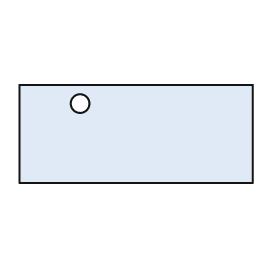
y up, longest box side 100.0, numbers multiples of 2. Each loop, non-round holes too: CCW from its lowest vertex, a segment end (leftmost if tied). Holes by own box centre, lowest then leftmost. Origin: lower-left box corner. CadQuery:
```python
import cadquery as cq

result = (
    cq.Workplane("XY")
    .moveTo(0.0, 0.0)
    .lineTo(100.0, 0.0)
    .lineTo(100.0, 42.0)
    .lineTo(0.0, 42.0)
    .close()
    .moveTo(26.0, 34.0)
    .circle(4.0)
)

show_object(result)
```